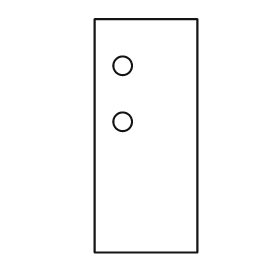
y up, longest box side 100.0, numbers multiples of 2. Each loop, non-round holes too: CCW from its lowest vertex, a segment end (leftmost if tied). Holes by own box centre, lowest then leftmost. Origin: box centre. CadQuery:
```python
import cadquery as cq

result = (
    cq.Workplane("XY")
    .moveTo(-22.0, -50.0)
    .lineTo(22.0, -50.0)
    .lineTo(22.0, 50.0)
    .lineTo(-22.0, 50.0)
    .close()
    .moveTo(-10.0, 6.0)
    .circle(4.0)
    .moveTo(-10.0, 30.0)
    .circle(4.0)
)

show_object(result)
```